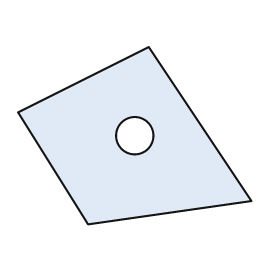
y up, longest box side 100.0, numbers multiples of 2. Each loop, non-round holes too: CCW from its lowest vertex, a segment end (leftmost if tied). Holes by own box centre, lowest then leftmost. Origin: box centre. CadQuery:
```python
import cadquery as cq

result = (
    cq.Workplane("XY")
    .moveTo(-20.0, -38.0)
    .lineTo(50.0, -28.0)
    .lineTo(6.0, 38.0)
    .lineTo(-50.0, 10.0)
    .close()
    .moveTo(0.0, 0.0)
    .circle(8.0)
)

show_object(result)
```